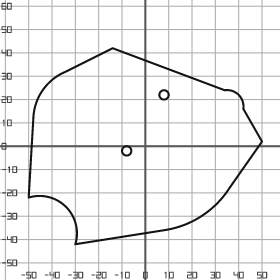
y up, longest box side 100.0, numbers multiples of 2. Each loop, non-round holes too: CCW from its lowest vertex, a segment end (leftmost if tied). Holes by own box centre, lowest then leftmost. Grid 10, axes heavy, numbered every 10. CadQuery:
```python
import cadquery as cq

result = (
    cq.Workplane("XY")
    .moveTo(-30.0, -42.0)
    .lineTo(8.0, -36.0)
    .threePointArc((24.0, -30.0), (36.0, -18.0))
    .lineTo(50.0, 2.0)
    .lineTo(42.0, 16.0)
    .threePointArc((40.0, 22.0), (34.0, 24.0))
    .lineTo(-14.0, 42.0)
    .lineTo(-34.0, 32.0)
    .threePointArc((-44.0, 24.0), (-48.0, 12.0))
    .lineTo(-50.0, -22.0)
    .threePointArc((-34.0, -26.0), (-30.0, -42.0))
    .close()
    .moveTo(-8.0, -2.0)
    .circle(2.0)
    .moveTo(8.0, 22.0)
    .circle(2.0)
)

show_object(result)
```